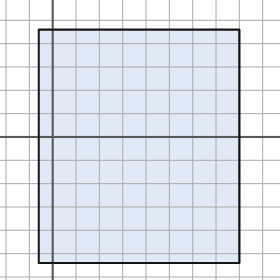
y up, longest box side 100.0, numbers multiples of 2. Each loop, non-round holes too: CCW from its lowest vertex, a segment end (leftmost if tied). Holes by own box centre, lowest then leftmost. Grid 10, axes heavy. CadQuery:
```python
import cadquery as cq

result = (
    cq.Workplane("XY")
    .moveTo(-6.0, -54.0)
    .lineTo(80.0, -54.0)
    .lineTo(80.0, 46.0)
    .lineTo(-6.0, 46.0)
    .close()
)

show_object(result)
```